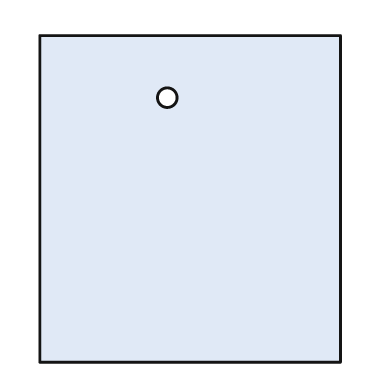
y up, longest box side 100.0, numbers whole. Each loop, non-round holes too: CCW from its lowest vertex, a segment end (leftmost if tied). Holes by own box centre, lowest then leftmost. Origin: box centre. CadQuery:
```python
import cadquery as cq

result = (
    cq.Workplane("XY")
    .moveTo(-46.0, -50.0)
    .lineTo(46.0, -50.0)
    .lineTo(46.0, 50.0)
    .lineTo(-46.0, 50.0)
    .close()
    .moveTo(-7.0, 31.0)
    .circle(3.0)
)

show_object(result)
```